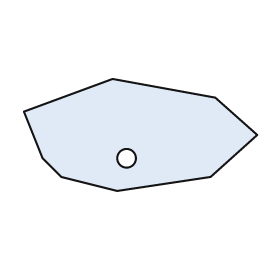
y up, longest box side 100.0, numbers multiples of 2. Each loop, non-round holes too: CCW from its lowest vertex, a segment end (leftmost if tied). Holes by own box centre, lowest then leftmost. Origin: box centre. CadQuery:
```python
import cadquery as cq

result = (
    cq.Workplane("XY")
    .moveTo(-10.0, -24.0)
    .lineTo(30.0, -18.0)
    .lineTo(50.0, 0.0)
    .lineTo(32.0, 16.0)
    .lineTo(-12.0, 24.0)
    .lineTo(-50.0, 10.0)
    .lineTo(-42.0, -10.0)
    .lineTo(-34.0, -18.0)
    .close()
    .moveTo(-6.0, -10.0)
    .circle(4.0)
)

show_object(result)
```